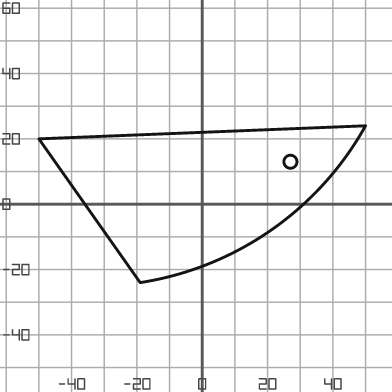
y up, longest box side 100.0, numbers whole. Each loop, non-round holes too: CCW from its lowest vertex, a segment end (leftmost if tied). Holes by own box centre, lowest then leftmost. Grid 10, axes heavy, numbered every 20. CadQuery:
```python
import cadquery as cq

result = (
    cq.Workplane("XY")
    .moveTo(-19.0, -24.0)
    .threePointArc((21.0, -8.0), (50.0, 24.0))
    .lineTo(-50.0, 20.0)
    .close()
    .moveTo(27.0, 13.0)
    .circle(2.0)
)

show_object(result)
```